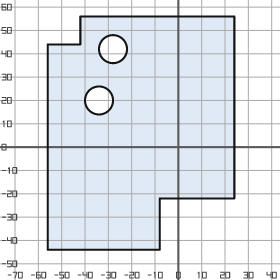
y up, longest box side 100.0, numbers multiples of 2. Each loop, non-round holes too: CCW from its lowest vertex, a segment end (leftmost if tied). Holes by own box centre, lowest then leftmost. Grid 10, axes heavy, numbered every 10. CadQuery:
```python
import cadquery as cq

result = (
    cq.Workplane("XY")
    .moveTo(-56.0, -44.0)
    .lineTo(-8.0, -44.0)
    .lineTo(-8.0, -22.0)
    .lineTo(24.0, -22.0)
    .lineTo(24.0, 56.0)
    .lineTo(-42.0, 56.0)
    .lineTo(-42.0, 44.0)
    .lineTo(-56.0, 44.0)
    .close()
    .moveTo(-34.0, 20.0)
    .circle(6.0)
    .moveTo(-28.0, 42.0)
    .circle(6.0)
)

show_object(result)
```